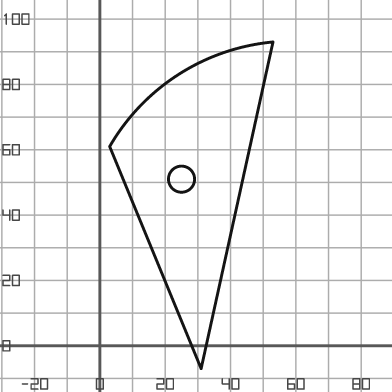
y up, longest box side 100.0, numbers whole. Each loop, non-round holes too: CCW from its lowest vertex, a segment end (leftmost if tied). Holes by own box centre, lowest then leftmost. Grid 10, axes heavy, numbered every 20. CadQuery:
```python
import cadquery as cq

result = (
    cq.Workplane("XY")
    .moveTo(31.0, -7.0)
    .lineTo(53.0, 93.0)
    .threePointArc((24.0, 83.0), (3.0, 61.0))
    .close()
    .moveTo(25.0, 51.0)
    .circle(4.0)
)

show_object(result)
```